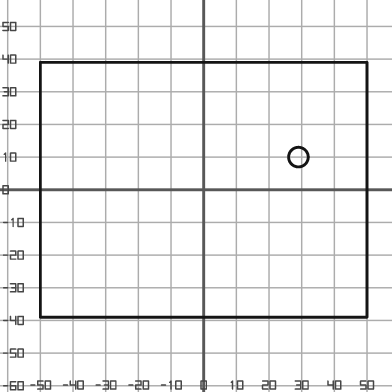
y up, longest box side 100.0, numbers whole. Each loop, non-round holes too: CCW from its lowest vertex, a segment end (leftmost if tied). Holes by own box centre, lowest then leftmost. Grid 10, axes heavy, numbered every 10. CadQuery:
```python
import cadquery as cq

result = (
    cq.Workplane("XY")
    .moveTo(-50.0, -39.0)
    .lineTo(50.0, -39.0)
    .lineTo(50.0, 39.0)
    .lineTo(-50.0, 39.0)
    .close()
    .moveTo(29.0, 10.0)
    .circle(3.0)
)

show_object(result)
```